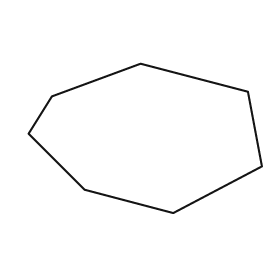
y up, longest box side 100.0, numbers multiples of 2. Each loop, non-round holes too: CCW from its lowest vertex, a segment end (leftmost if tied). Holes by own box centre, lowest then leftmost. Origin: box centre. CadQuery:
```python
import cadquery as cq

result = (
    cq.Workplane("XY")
    .moveTo(12.0, -32.0)
    .lineTo(50.0, -12.0)
    .lineTo(44.0, 20.0)
    .lineTo(-2.0, 32.0)
    .lineTo(-40.0, 18.0)
    .lineTo(-50.0, 2.0)
    .lineTo(-26.0, -22.0)
    .close()
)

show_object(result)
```